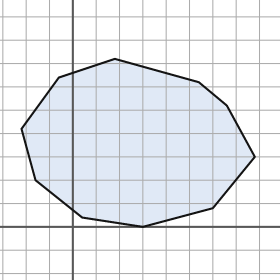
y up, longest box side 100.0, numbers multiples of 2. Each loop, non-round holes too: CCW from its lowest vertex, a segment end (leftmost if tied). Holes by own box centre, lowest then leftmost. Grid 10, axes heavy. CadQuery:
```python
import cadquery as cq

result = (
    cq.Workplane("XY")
    .moveTo(30.0, 0.0)
    .lineTo(60.0, 8.0)
    .lineTo(78.0, 30.0)
    .lineTo(66.0, 52.0)
    .lineTo(54.0, 62.0)
    .lineTo(18.0, 72.0)
    .lineTo(-6.0, 64.0)
    .lineTo(-22.0, 42.0)
    .lineTo(-16.0, 20.0)
    .lineTo(4.0, 4.0)
    .close()
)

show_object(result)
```